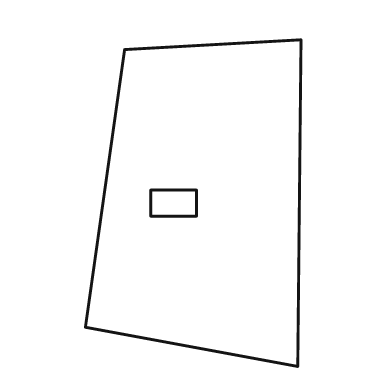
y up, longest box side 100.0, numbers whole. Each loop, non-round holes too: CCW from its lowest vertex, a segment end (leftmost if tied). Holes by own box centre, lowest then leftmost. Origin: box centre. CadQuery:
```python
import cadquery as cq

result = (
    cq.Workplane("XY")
    .moveTo(32.0, -50.0)
    .lineTo(33.0, 50.0)
    .lineTo(-21.0, 47.0)
    .lineTo(-33.0, -38.0)
    .close()
    .moveTo(-13.0, -4.0)
    .lineTo(1.0, -4.0)
    .lineTo(1.0, 4.0)
    .lineTo(-13.0, 4.0)
    .close()
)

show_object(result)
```